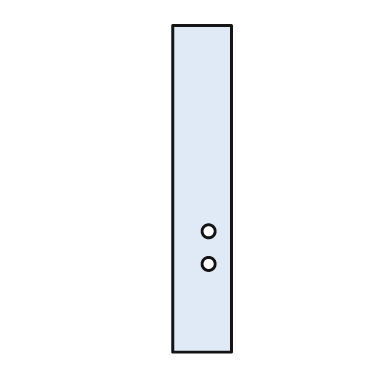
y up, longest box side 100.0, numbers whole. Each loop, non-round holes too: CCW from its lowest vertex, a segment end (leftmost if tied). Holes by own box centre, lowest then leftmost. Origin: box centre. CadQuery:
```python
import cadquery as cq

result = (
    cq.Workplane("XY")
    .moveTo(-9.0, -50.0)
    .lineTo(9.0, -50.0)
    .lineTo(9.0, 50.0)
    .lineTo(-9.0, 50.0)
    .close()
    .moveTo(2.0, -23.0)
    .circle(2.0)
    .moveTo(2.0, -13.0)
    .circle(2.0)
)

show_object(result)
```